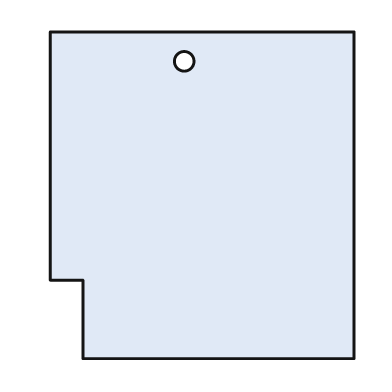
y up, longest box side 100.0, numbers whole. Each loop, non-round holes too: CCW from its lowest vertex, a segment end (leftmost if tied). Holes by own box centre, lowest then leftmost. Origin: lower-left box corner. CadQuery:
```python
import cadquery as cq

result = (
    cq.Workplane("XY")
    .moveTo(10.0, 0.0)
    .lineTo(93.0, 0.0)
    .lineTo(93.0, 100.0)
    .lineTo(0.0, 100.0)
    .lineTo(0.0, 24.0)
    .lineTo(10.0, 24.0)
    .close()
    .moveTo(41.0, 91.0)
    .circle(3.0)
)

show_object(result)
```